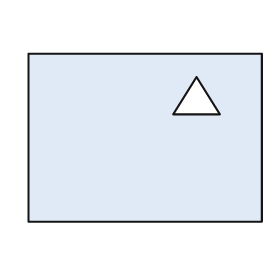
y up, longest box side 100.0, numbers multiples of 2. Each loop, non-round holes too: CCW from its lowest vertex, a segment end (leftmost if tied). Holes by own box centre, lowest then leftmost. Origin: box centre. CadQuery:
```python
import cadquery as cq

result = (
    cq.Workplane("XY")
    .moveTo(-50.0, -36.0)
    .lineTo(50.0, -36.0)
    .lineTo(50.0, 36.0)
    .lineTo(-50.0, 36.0)
    .close()
    .moveTo(12.0, 10.0)
    .lineTo(32.0, 10.0)
    .lineTo(22.0, 26.0)
    .close()
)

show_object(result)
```